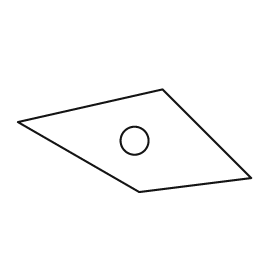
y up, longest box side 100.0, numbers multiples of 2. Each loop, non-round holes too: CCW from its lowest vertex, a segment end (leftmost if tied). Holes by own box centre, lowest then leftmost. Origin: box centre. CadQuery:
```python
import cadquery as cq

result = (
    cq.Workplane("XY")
    .moveTo(2.0, -22.0)
    .lineTo(50.0, -16.0)
    .lineTo(12.0, 22.0)
    .lineTo(-50.0, 8.0)
    .close()
    .moveTo(0.0, 0.0)
    .circle(6.0)
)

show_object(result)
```